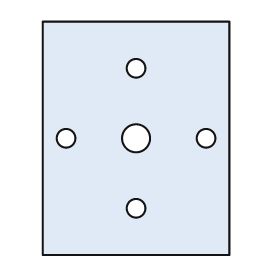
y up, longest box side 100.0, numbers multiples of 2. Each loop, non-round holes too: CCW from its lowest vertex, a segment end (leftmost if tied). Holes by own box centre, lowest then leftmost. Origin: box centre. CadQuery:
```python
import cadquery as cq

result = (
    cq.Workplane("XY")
    .moveTo(-40.0, -50.0)
    .lineTo(40.0, -50.0)
    .lineTo(40.0, 50.0)
    .lineTo(-40.0, 50.0)
    .close()
    .moveTo(0.0, -30.0)
    .circle(4.0)
    .moveTo(-30.0, 0.0)
    .circle(4.0)
    .moveTo(0.0, 0.0)
    .circle(6.0)
    .moveTo(30.0, 0.0)
    .circle(4.0)
    .moveTo(0.0, 30.0)
    .circle(4.0)
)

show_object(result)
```